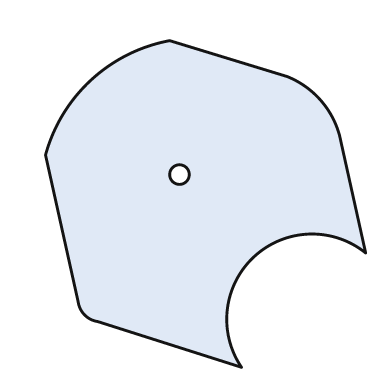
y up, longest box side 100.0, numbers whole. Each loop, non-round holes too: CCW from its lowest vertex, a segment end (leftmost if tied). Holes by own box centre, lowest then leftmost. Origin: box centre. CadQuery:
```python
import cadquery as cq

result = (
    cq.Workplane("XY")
    .moveTo(11.0, -50.0)
    .threePointArc((15.0, -16.0), (49.0, -15.0))
    .lineTo(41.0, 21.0)
    .threePointArc((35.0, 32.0), (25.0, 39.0))
    .lineTo(-11.0, 50.0)
    .threePointArc((-35.0, 38.0), (-49.0, 15.0))
    .lineTo(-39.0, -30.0)
    .threePointArc((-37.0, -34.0), (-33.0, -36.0))
    .close()
    .moveTo(-8.0, 9.0)
    .circle(3.0)
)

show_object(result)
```